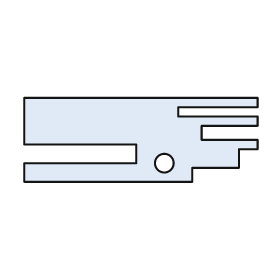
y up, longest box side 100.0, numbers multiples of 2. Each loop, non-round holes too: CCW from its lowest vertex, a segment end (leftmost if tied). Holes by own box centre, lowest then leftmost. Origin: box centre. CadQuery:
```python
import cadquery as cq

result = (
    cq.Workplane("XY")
    .moveTo(-50.0, -18.0)
    .lineTo(22.0, -18.0)
    .lineTo(22.0, -12.0)
    .lineTo(42.0, -12.0)
    .lineTo(42.0, -4.0)
    .lineTo(50.0, -4.0)
    .lineTo(50.0, 0.0)
    .lineTo(26.0, 0.0)
    .lineTo(26.0, 6.0)
    .lineTo(50.0, 6.0)
    .lineTo(50.0, 10.0)
    .lineTo(16.0, 10.0)
    .lineTo(16.0, 14.0)
    .lineTo(50.0, 14.0)
    .lineTo(50.0, 18.0)
    .lineTo(-50.0, 18.0)
    .lineTo(-50.0, -2.0)
    .lineTo(-2.0, -2.0)
    .lineTo(-2.0, -10.0)
    .lineTo(-50.0, -10.0)
    .close()
    .moveTo(10.0, -10.0)
    .circle(4.0)
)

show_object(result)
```